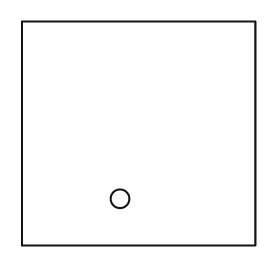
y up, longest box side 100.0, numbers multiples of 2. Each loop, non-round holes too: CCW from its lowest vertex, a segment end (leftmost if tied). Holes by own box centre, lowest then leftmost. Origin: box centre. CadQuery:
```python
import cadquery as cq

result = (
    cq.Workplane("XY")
    .moveTo(-50.0, -48.0)
    .lineTo(50.0, -48.0)
    .lineTo(50.0, 48.0)
    .lineTo(-50.0, 48.0)
    .close()
    .moveTo(-8.0, -28.0)
    .circle(4.0)
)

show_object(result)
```